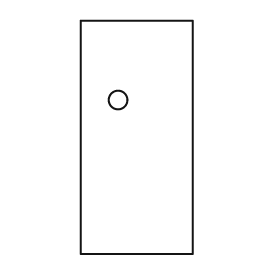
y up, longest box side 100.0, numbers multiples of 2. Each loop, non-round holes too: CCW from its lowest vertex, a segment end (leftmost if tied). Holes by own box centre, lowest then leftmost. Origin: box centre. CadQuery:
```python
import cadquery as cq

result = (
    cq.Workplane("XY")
    .moveTo(-24.0, -50.0)
    .lineTo(24.0, -50.0)
    .lineTo(24.0, 50.0)
    .lineTo(-24.0, 50.0)
    .close()
    .moveTo(-8.0, 16.0)
    .circle(4.0)
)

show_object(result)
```